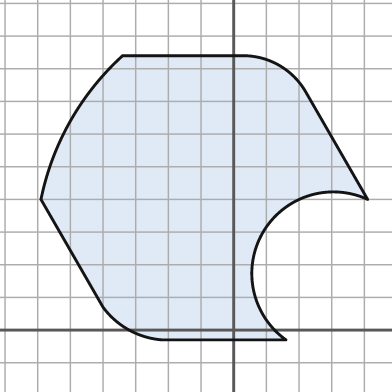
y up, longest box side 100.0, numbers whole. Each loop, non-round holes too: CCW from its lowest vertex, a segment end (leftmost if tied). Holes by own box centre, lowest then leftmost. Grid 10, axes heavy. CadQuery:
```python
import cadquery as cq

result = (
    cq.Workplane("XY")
    .moveTo(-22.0, -3.0)
    .lineTo(16.0, -3.0)
    .threePointArc((9.0, 30.0), (41.0, 40.0))
    .lineTo(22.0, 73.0)
    .threePointArc((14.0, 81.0), (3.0, 84.0))
    .lineTo(-34.0, 84.0)
    .threePointArc((-50.0, 64.0), (-59.0, 40.0))
    .lineTo(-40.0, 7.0)
    .threePointArc((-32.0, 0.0), (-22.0, -3.0))
    .close()
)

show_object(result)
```